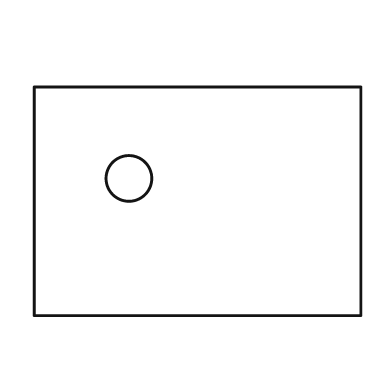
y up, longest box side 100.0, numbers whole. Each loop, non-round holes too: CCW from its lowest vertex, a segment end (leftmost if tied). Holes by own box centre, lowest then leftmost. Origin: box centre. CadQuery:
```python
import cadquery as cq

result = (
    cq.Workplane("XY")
    .moveTo(-50.0, -35.0)
    .lineTo(50.0, -35.0)
    .lineTo(50.0, 35.0)
    .lineTo(-50.0, 35.0)
    .close()
    .moveTo(-21.0, 7.0)
    .circle(7.0)
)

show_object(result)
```